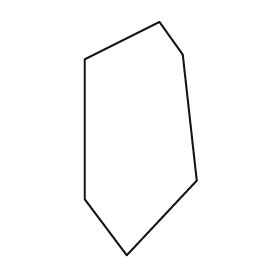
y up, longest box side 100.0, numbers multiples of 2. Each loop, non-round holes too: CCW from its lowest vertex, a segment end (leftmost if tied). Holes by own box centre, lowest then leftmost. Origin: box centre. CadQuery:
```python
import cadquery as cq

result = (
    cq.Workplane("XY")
    .moveTo(-6.0, -50.0)
    .lineTo(24.0, -18.0)
    .lineTo(18.0, 36.0)
    .lineTo(8.0, 50.0)
    .lineTo(-24.0, 34.0)
    .lineTo(-24.0, -26.0)
    .close()
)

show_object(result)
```